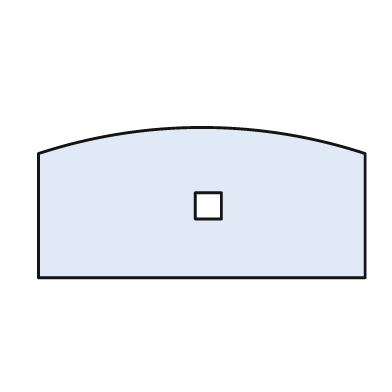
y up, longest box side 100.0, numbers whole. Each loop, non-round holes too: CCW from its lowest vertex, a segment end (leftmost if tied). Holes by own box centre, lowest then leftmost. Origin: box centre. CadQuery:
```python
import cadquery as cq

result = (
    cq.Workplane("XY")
    .moveTo(-50.0, -23.0)
    .lineTo(50.0, -23.0)
    .lineTo(50.0, 15.0)
    .threePointArc((0.0, 23.0), (-50.0, 15.0))
    .close()
    .moveTo(-2.0, -5.0)
    .lineTo(6.0, -5.0)
    .lineTo(6.0, 3.0)
    .lineTo(-2.0, 3.0)
    .close()
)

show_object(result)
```